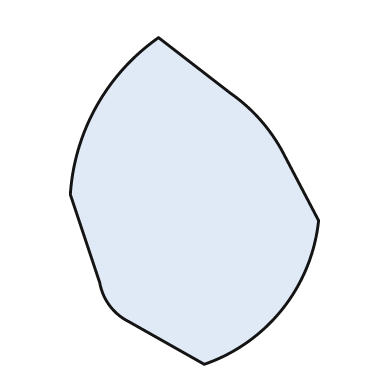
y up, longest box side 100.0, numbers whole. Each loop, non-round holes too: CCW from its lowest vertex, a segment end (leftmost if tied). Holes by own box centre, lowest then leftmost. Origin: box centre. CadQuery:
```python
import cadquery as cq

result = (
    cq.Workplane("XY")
    .moveTo(3.0, -50.0)
    .threePointArc((27.0, -33.0), (38.0, -6.0))
    .lineTo(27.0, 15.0)
    .threePointArc((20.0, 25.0), (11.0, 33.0))
    .lineTo(-11.0, 50.0)
    .threePointArc((-30.0, 29.0), (-38.0, 2.0))
    .lineTo(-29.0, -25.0)
    .threePointArc((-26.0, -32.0), (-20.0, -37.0))
    .close()
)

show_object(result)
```